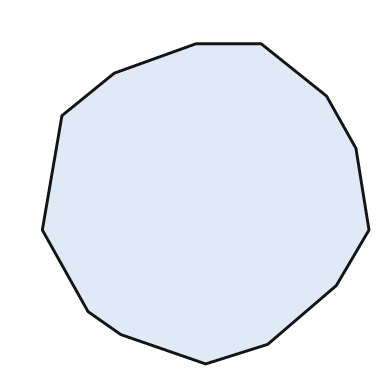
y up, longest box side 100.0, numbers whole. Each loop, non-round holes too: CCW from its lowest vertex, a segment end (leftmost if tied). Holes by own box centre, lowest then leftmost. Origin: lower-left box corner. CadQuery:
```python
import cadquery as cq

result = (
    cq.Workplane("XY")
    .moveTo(50.0, 0.0)
    .lineTo(69.0, 6.0)
    .lineTo(90.0, 24.0)
    .lineTo(100.0, 41.0)
    .lineTo(96.0, 66.0)
    .lineTo(87.0, 82.0)
    .lineTo(67.0, 98.0)
    .lineTo(47.0, 98.0)
    .lineTo(22.0, 89.0)
    .lineTo(6.0, 76.0)
    .lineTo(0.0, 41.0)
    .lineTo(14.0, 16.0)
    .lineTo(24.0, 9.0)
    .close()
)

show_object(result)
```